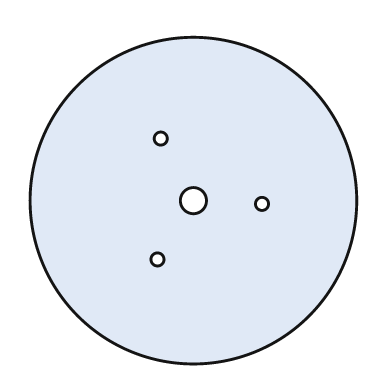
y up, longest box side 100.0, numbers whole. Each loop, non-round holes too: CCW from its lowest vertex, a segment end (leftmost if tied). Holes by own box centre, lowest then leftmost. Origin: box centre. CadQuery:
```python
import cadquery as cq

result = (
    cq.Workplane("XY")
    .moveTo(0.0, 0.0)
    .circle(50.0)
    .moveTo(-11.0, -18.0)
    .circle(2.0)
    .moveTo(21.0, -1.0)
    .circle(2.0)
    .moveTo(0.0, 0.0)
    .circle(4.0)
    .moveTo(-10.0, 19.0)
    .circle(2.0)
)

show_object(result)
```